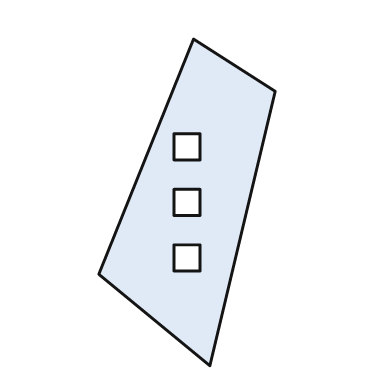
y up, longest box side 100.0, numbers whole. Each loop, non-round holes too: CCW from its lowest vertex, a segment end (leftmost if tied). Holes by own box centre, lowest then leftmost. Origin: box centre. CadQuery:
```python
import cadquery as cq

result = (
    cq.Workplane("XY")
    .moveTo(7.0, -50.0)
    .lineTo(27.0, 34.0)
    .lineTo(2.0, 50.0)
    .lineTo(-27.0, -22.0)
    .close()
    .moveTo(-4.0, -21.0)
    .lineTo(4.0, -21.0)
    .lineTo(4.0, -13.0)
    .lineTo(-4.0, -13.0)
    .close()
    .moveTo(-4.0, -4.0)
    .lineTo(4.0, -4.0)
    .lineTo(4.0, 4.0)
    .lineTo(-4.0, 4.0)
    .close()
    .moveTo(-4.0, 13.0)
    .lineTo(4.0, 13.0)
    .lineTo(4.0, 21.0)
    .lineTo(-4.0, 21.0)
    .close()
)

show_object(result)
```